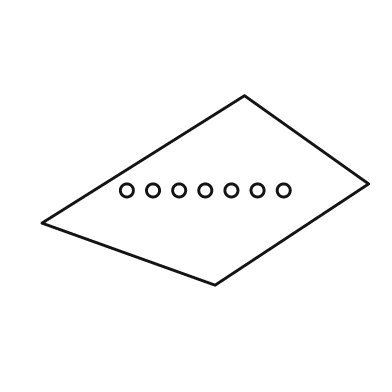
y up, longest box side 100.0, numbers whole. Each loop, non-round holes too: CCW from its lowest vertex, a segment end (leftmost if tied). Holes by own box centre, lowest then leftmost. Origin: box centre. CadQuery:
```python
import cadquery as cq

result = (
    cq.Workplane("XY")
    .moveTo(3.0, -29.0)
    .lineTo(50.0, 2.0)
    .lineTo(12.0, 29.0)
    .lineTo(-50.0, -10.0)
    .close()
    .moveTo(-24.0, 0.0)
    .circle(2.0)
    .moveTo(-16.0, 0.0)
    .circle(2.0)
    .moveTo(-8.0, 0.0)
    .circle(2.0)
    .moveTo(0.0, 0.0)
    .circle(2.0)
    .moveTo(8.0, 0.0)
    .circle(2.0)
    .moveTo(16.0, 0.0)
    .circle(2.0)
    .moveTo(24.0, 0.0)
    .circle(2.0)
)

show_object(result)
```